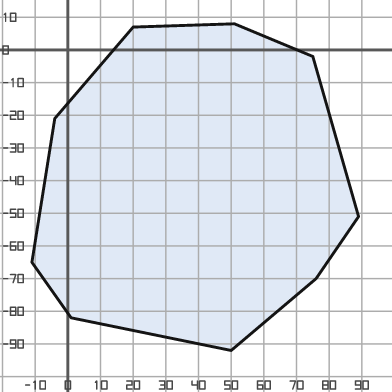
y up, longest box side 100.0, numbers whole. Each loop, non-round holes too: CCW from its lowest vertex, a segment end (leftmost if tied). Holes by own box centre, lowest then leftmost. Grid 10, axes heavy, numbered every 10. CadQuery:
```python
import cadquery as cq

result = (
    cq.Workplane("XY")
    .moveTo(50.0, -92.0)
    .lineTo(76.0, -70.0)
    .lineTo(89.0, -51.0)
    .lineTo(75.0, -2.0)
    .lineTo(51.0, 8.0)
    .lineTo(20.0, 7.0)
    .lineTo(-4.0, -21.0)
    .lineTo(-11.0, -65.0)
    .lineTo(1.0, -82.0)
    .close()
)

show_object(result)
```